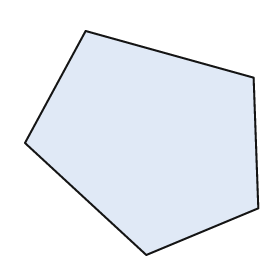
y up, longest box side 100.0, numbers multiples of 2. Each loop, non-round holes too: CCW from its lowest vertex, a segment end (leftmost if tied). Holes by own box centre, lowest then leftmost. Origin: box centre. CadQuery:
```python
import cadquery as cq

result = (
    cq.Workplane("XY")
    .moveTo(2.0, -48.0)
    .lineTo(50.0, -28.0)
    .lineTo(48.0, 28.0)
    .lineTo(-24.0, 48.0)
    .lineTo(-50.0, 0.0)
    .close()
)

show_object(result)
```